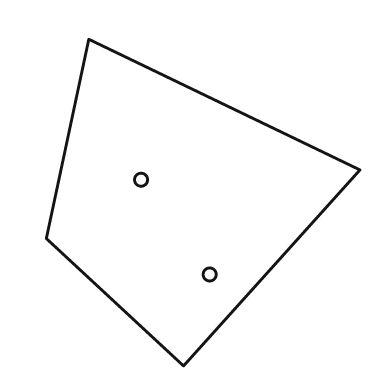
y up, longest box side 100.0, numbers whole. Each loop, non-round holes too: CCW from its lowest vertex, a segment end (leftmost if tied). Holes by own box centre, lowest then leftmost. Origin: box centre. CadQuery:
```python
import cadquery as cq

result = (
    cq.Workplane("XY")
    .moveTo(-6.0, -50.0)
    .lineTo(48.0, 10.0)
    .lineTo(-35.0, 50.0)
    .lineTo(-48.0, -11.0)
    .close()
    .moveTo(2.0, -22.0)
    .circle(2.0)
    .moveTo(-19.0, 7.0)
    .circle(2.0)
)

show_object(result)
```